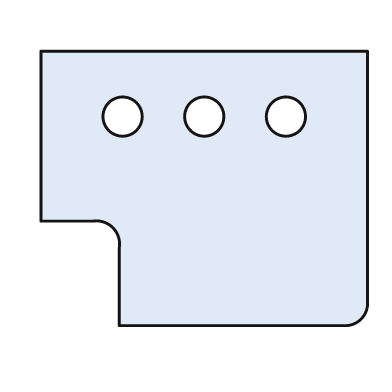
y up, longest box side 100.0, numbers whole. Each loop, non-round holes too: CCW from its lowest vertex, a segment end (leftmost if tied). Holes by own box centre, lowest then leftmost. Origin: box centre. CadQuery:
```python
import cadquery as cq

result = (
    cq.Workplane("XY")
    .moveTo(-26.0, -42.0)
    .lineTo(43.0, -42.0)
    .threePointArc((48.0, -40.0), (50.0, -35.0))
    .lineTo(50.0, 42.0)
    .lineTo(-50.0, 42.0)
    .lineTo(-50.0, -10.0)
    .lineTo(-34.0, -10.0)
    .threePointArc((-28.0, -12.0), (-26.0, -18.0))
    .close()
    .moveTo(-25.0, 22.0)
    .circle(6.0)
    .moveTo(0.0, 22.0)
    .circle(6.0)
    .moveTo(25.0, 22.0)
    .circle(6.0)
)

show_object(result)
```